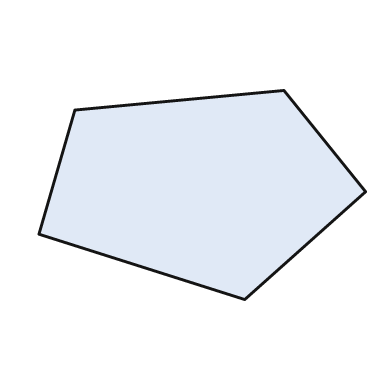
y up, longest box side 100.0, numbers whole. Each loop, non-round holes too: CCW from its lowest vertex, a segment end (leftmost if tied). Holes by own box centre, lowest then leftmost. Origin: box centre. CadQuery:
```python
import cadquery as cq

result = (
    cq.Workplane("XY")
    .moveTo(13.0, -32.0)
    .lineTo(50.0, 1.0)
    .lineTo(25.0, 32.0)
    .lineTo(-39.0, 26.0)
    .lineTo(-50.0, -12.0)
    .close()
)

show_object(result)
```